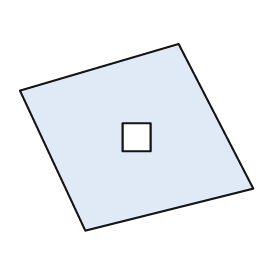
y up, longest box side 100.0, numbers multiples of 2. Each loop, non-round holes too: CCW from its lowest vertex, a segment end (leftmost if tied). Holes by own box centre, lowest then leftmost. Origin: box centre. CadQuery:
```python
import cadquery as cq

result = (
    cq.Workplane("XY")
    .moveTo(-22.0, -40.0)
    .lineTo(50.0, -22.0)
    .lineTo(18.0, 40.0)
    .lineTo(-50.0, 20.0)
    .close()
    .moveTo(-6.0, -6.0)
    .lineTo(6.0, -6.0)
    .lineTo(6.0, 6.0)
    .lineTo(-6.0, 6.0)
    .close()
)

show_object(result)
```